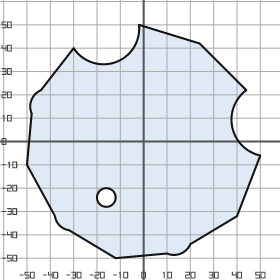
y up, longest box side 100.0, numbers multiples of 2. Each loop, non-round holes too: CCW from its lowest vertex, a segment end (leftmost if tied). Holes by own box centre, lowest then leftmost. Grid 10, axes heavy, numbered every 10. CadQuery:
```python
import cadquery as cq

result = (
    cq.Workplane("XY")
    .moveTo(-12.0, -50.0)
    .lineTo(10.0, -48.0)
    .threePointArc((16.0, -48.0), (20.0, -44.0))
    .lineTo(40.0, -32.0)
    .lineTo(50.0, -6.0)
    .threePointArc((38.0, 6.0), (44.0, 22.0))
    .lineTo(24.0, 42.0)
    .lineTo(-2.0, 50.0)
    .threePointArc((-12.0, 34.0), (-30.0, 40.0))
    .lineTo(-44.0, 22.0)
    .threePointArc((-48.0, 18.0), (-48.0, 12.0))
    .lineTo(-50.0, -10.0)
    .lineTo(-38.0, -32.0)
    .threePointArc((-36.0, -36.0), (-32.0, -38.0))
    .close()
    .moveTo(-16.0, -24.0)
    .circle(4.0)
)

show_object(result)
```